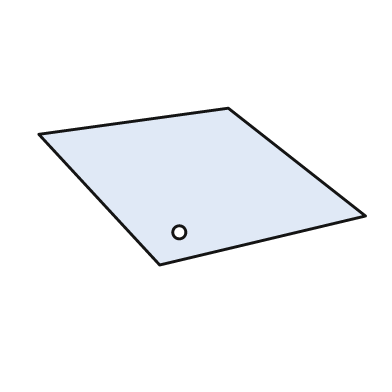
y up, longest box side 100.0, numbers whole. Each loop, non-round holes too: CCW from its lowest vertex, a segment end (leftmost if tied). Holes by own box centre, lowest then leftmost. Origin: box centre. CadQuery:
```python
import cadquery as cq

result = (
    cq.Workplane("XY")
    .moveTo(-13.0, -24.0)
    .lineTo(50.0, -9.0)
    .lineTo(8.0, 24.0)
    .lineTo(-50.0, 16.0)
    .close()
    .moveTo(-7.0, -14.0)
    .circle(2.0)
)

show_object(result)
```